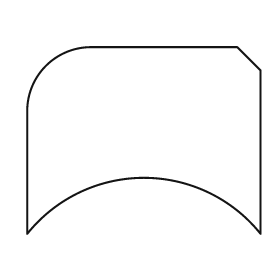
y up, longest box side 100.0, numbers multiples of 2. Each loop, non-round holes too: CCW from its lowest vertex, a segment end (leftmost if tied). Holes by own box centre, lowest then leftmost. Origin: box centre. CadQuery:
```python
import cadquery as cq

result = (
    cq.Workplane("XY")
    .moveTo(-50.0, -40.0)
    .threePointArc((0.0, -16.0), (50.0, -40.0))
    .lineTo(50.0, 30.0)
    .lineTo(40.0, 40.0)
    .lineTo(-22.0, 40.0)
    .threePointArc((-42.0, 32.0), (-50.0, 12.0))
    .close()
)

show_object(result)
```